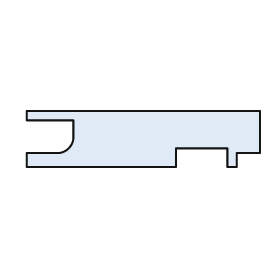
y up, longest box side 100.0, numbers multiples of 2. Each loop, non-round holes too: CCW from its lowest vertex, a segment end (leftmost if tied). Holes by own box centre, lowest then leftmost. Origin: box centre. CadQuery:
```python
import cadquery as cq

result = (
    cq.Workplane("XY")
    .moveTo(-50.0, -12.0)
    .lineTo(14.0, -12.0)
    .lineTo(14.0, -4.0)
    .lineTo(36.0, -4.0)
    .lineTo(36.0, -12.0)
    .lineTo(40.0, -12.0)
    .lineTo(40.0, -6.0)
    .lineTo(50.0, -6.0)
    .lineTo(50.0, 12.0)
    .lineTo(-50.0, 12.0)
    .lineTo(-50.0, 8.0)
    .lineTo(-30.0, 8.0)
    .lineTo(-30.0, 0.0)
    .threePointArc((-32.0, -4.0), (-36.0, -6.0))
    .lineTo(-50.0, -6.0)
    .close()
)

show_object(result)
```